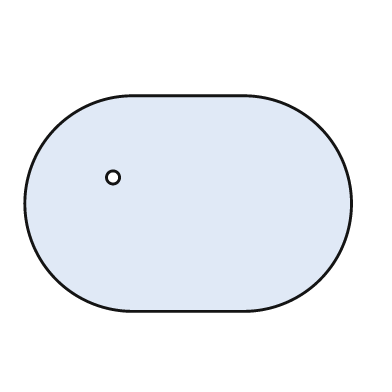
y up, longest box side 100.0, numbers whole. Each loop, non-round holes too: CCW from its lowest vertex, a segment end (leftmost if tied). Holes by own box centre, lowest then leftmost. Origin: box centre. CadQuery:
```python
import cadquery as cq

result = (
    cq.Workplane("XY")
    .moveTo(-17.0, -33.0)
    .lineTo(17.0, -33.0)
    .threePointArc((50.0, 0.0), (17.0, 33.0))
    .lineTo(-17.0, 33.0)
    .threePointArc((-50.0, 0.0), (-17.0, -33.0))
    .close()
    .moveTo(-23.0, 8.0)
    .circle(2.0)
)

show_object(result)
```